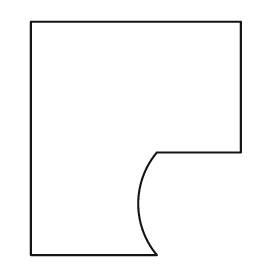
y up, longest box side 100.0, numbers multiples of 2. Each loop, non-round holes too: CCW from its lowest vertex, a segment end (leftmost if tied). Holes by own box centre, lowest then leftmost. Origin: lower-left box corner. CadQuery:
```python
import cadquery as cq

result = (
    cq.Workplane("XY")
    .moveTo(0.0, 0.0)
    .lineTo(54.0, 0.0)
    .threePointArc((46.0, 22.0), (54.0, 44.0))
    .lineTo(90.0, 44.0)
    .lineTo(90.0, 100.0)
    .lineTo(0.0, 100.0)
    .close()
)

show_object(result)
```